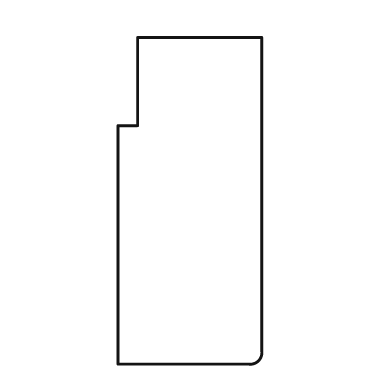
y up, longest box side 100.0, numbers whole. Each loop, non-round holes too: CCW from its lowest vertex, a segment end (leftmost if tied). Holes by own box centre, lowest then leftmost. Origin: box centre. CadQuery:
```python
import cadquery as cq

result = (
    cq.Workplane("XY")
    .moveTo(-22.0, -50.0)
    .lineTo(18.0, -50.0)
    .threePointArc((21.0, -49.0), (22.0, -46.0))
    .lineTo(22.0, 50.0)
    .lineTo(-16.0, 50.0)
    .lineTo(-16.0, 23.0)
    .lineTo(-22.0, 23.0)
    .close()
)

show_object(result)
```